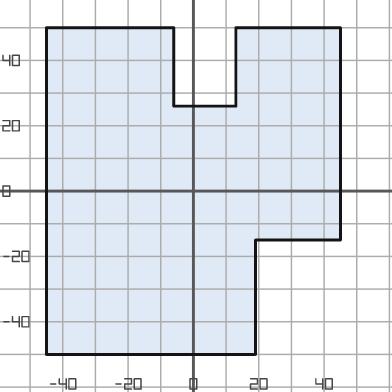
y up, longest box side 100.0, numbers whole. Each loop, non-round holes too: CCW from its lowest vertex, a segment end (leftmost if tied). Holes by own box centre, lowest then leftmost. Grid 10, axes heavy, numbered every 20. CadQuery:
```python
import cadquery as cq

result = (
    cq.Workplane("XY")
    .moveTo(-45.0, -50.0)
    .lineTo(19.0, -50.0)
    .lineTo(19.0, -15.0)
    .lineTo(45.0, -15.0)
    .lineTo(45.0, 50.0)
    .lineTo(13.0, 50.0)
    .lineTo(13.0, 26.0)
    .lineTo(-6.0, 26.0)
    .lineTo(-6.0, 50.0)
    .lineTo(-45.0, 50.0)
    .close()
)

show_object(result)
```